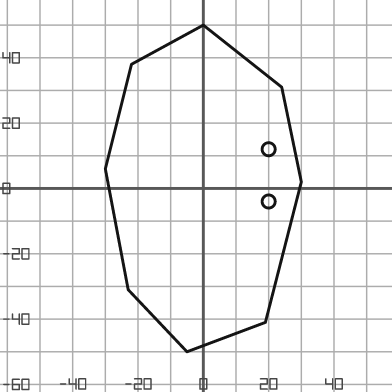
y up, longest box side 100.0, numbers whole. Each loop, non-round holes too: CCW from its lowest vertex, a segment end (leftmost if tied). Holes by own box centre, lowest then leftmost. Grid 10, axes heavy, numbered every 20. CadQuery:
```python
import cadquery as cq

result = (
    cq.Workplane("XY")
    .moveTo(-5.0, -50.0)
    .lineTo(19.0, -41.0)
    .lineTo(30.0, 2.0)
    .lineTo(24.0, 31.0)
    .lineTo(0.0, 50.0)
    .lineTo(-22.0, 38.0)
    .lineTo(-30.0, 6.0)
    .lineTo(-23.0, -31.0)
    .close()
    .moveTo(20.0, -4.0)
    .circle(2.0)
    .moveTo(20.0, 12.0)
    .circle(2.0)
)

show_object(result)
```